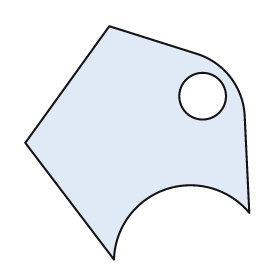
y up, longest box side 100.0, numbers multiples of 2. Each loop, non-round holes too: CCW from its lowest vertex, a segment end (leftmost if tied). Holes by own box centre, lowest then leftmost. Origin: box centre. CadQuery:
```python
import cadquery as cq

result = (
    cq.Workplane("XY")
    .moveTo(-10.0, -50.0)
    .threePointArc((12.0, -20.0), (48.0, -30.0))
    .lineTo(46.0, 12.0)
    .threePointArc((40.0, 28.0), (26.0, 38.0))
    .lineTo(-12.0, 50.0)
    .lineTo(-48.0, 0.0)
    .close()
    .moveTo(28.0, 20.0)
    .circle(10.0)
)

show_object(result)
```